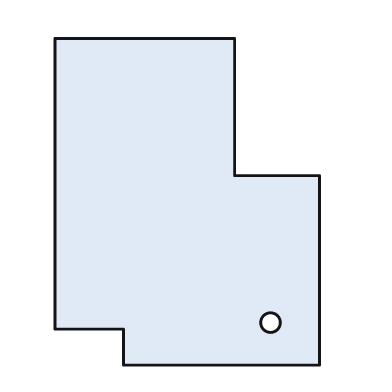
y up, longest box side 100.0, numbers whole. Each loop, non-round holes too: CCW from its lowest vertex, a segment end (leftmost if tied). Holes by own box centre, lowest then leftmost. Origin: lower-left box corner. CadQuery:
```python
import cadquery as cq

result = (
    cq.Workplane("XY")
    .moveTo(21.0, 0.0)
    .lineTo(81.0, 0.0)
    .lineTo(81.0, 58.0)
    .lineTo(55.0, 58.0)
    .lineTo(55.0, 100.0)
    .lineTo(0.0, 100.0)
    .lineTo(0.0, 11.0)
    .lineTo(21.0, 11.0)
    .close()
    .moveTo(66.0, 13.0)
    .circle(3.0)
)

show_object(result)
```